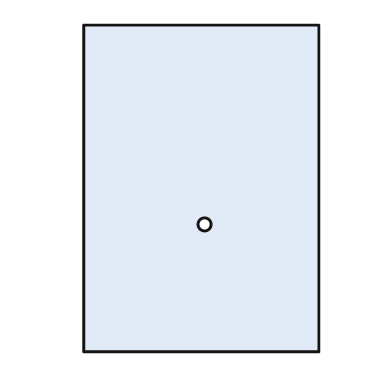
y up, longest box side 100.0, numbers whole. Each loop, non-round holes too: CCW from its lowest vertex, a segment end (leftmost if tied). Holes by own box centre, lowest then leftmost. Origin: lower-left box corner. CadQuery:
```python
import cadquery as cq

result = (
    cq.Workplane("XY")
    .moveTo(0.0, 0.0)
    .lineTo(72.0, 0.0)
    .lineTo(72.0, 100.0)
    .lineTo(0.0, 100.0)
    .close()
    .moveTo(37.0, 39.0)
    .circle(2.0)
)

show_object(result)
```